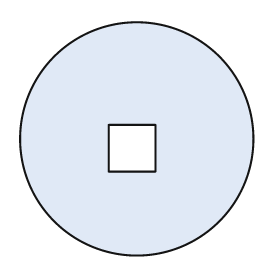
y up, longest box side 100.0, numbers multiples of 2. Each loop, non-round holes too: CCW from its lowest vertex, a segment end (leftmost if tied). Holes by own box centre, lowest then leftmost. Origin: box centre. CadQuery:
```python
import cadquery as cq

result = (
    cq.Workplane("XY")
    .moveTo(0.0, 0.0)
    .circle(50.0)
    .moveTo(-12.0, -14.0)
    .lineTo(8.0, -14.0)
    .lineTo(8.0, 6.0)
    .lineTo(-12.0, 6.0)
    .close()
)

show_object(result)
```